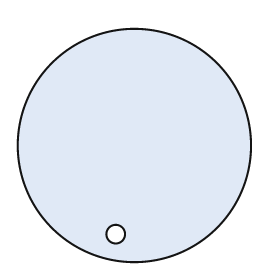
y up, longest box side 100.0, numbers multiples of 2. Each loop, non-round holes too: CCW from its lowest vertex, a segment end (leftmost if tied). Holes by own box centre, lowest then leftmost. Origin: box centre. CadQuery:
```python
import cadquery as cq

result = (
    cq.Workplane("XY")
    .moveTo(0.0, 0.0)
    .circle(50.0)
    .moveTo(-8.0, -38.0)
    .circle(4.0)
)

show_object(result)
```